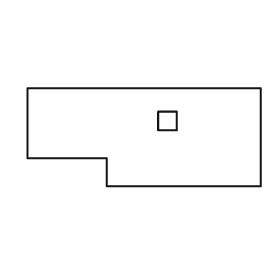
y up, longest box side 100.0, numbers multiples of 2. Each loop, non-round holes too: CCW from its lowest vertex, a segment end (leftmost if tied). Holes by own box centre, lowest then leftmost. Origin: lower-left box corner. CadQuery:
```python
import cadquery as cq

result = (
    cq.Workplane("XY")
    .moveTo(34.0, 0.0)
    .lineTo(100.0, 0.0)
    .lineTo(100.0, 42.0)
    .lineTo(0.0, 42.0)
    .lineTo(0.0, 12.0)
    .lineTo(34.0, 12.0)
    .close()
    .moveTo(56.0, 24.0)
    .lineTo(64.0, 24.0)
    .lineTo(64.0, 32.0)
    .lineTo(56.0, 32.0)
    .close()
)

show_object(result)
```